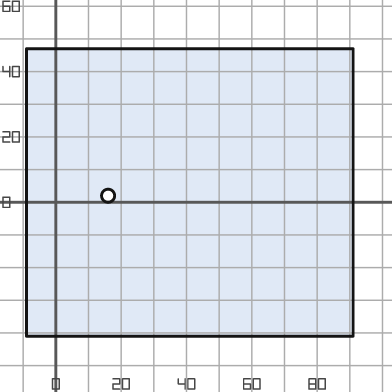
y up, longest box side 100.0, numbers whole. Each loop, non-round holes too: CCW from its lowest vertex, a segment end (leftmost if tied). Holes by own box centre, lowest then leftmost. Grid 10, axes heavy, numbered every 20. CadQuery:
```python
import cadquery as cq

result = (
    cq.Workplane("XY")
    .moveTo(-9.0, -41.0)
    .lineTo(91.0, -41.0)
    .lineTo(91.0, 47.0)
    .lineTo(-9.0, 47.0)
    .close()
    .moveTo(16.0, 2.0)
    .circle(2.0)
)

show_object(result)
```